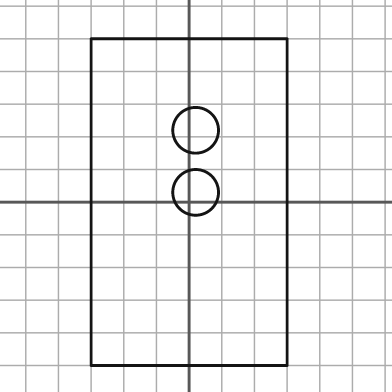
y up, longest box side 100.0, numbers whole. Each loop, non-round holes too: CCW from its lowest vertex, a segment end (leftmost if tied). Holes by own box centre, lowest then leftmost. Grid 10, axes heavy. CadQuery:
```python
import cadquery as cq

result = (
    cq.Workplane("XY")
    .moveTo(-30.0, -50.0)
    .lineTo(30.0, -50.0)
    .lineTo(30.0, 50.0)
    .lineTo(-30.0, 50.0)
    .close()
    .moveTo(2.0, 3.0)
    .circle(7.0)
    .moveTo(2.0, 22.0)
    .circle(7.0)
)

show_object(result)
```